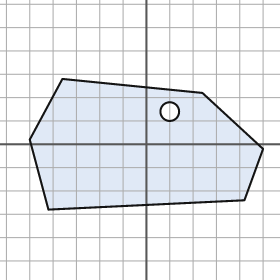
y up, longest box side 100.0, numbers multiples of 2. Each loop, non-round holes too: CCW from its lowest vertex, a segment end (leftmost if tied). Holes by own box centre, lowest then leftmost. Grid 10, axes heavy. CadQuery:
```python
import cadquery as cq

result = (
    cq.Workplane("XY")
    .moveTo(-42.0, -28.0)
    .lineTo(42.0, -24.0)
    .lineTo(50.0, -2.0)
    .lineTo(24.0, 22.0)
    .lineTo(-36.0, 28.0)
    .lineTo(-50.0, 2.0)
    .close()
    .moveTo(10.0, 14.0)
    .circle(4.0)
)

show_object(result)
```